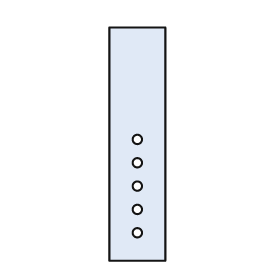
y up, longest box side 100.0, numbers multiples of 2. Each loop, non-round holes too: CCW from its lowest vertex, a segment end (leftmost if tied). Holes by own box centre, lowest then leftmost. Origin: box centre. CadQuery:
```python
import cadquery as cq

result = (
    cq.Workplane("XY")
    .moveTo(-12.0, -50.0)
    .lineTo(12.0, -50.0)
    .lineTo(12.0, 50.0)
    .lineTo(-12.0, 50.0)
    .close()
    .moveTo(0.0, -38.0)
    .circle(2.0)
    .moveTo(0.0, -28.0)
    .circle(2.0)
    .moveTo(0.0, -18.0)
    .circle(2.0)
    .moveTo(0.0, -8.0)
    .circle(2.0)
    .moveTo(0.0, 2.0)
    .circle(2.0)
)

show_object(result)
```